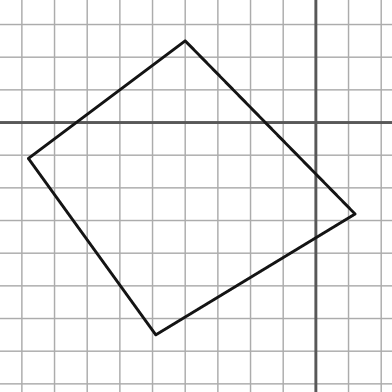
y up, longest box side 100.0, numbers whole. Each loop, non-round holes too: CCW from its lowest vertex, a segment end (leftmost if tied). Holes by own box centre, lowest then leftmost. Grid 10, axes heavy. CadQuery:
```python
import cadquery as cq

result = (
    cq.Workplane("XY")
    .moveTo(-49.0, -65.0)
    .lineTo(12.0, -28.0)
    .lineTo(-40.0, 25.0)
    .lineTo(-88.0, -11.0)
    .close()
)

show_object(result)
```